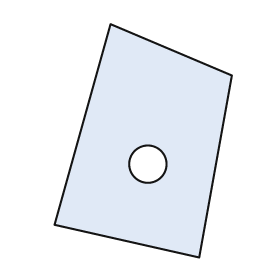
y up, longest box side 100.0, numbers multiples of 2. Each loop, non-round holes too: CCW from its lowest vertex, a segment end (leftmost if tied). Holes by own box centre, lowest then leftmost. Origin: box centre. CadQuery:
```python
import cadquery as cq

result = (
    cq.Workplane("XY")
    .moveTo(24.0, -50.0)
    .lineTo(38.0, 28.0)
    .lineTo(-14.0, 50.0)
    .lineTo(-38.0, -36.0)
    .close()
    .moveTo(2.0, -10.0)
    .circle(8.0)
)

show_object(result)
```